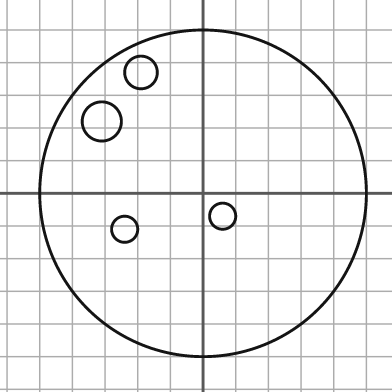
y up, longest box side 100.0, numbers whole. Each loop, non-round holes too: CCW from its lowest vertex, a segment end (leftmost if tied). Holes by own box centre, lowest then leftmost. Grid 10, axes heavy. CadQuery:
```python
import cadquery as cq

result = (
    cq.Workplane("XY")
    .moveTo(0.0, 0.0)
    .circle(50.0)
    .moveTo(-24.0, -11.0)
    .circle(4.0)
    .moveTo(6.0, -7.0)
    .circle(4.0)
    .moveTo(-31.0, 22.0)
    .circle(6.0)
    .moveTo(-19.0, 37.0)
    .circle(5.0)
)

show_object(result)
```